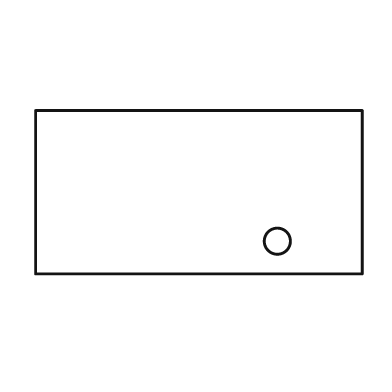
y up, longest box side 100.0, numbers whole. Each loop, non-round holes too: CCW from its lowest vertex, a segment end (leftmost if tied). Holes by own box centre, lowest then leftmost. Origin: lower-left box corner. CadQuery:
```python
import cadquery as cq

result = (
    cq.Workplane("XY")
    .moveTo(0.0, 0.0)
    .lineTo(100.0, 0.0)
    .lineTo(100.0, 50.0)
    .lineTo(0.0, 50.0)
    .close()
    .moveTo(74.0, 10.0)
    .circle(4.0)
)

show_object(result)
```